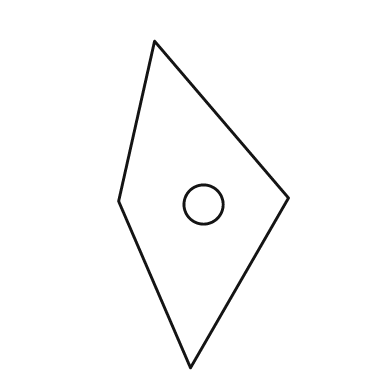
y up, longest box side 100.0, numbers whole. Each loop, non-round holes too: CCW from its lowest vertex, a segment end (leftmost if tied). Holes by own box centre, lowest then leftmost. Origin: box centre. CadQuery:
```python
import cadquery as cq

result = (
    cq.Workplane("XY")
    .moveTo(-4.0, -50.0)
    .lineTo(26.0, 2.0)
    .lineTo(-15.0, 50.0)
    .lineTo(-26.0, 1.0)
    .close()
    .moveTo(0.0, 0.0)
    .circle(6.0)
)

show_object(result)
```